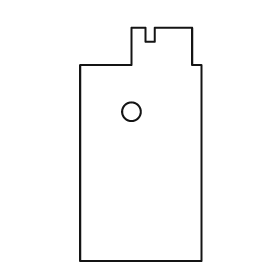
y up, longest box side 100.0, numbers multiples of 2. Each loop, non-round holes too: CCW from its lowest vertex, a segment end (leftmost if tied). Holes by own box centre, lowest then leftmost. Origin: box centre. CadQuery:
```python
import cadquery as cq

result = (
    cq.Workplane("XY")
    .moveTo(-26.0, -50.0)
    .lineTo(26.0, -50.0)
    .lineTo(26.0, 34.0)
    .lineTo(22.0, 34.0)
    .lineTo(22.0, 50.0)
    .lineTo(6.0, 50.0)
    .lineTo(6.0, 44.0)
    .lineTo(2.0, 44.0)
    .lineTo(2.0, 50.0)
    .lineTo(-4.0, 50.0)
    .lineTo(-4.0, 34.0)
    .lineTo(-26.0, 34.0)
    .close()
    .moveTo(-4.0, 14.0)
    .circle(4.0)
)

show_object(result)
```